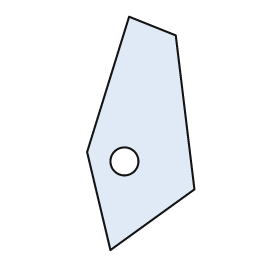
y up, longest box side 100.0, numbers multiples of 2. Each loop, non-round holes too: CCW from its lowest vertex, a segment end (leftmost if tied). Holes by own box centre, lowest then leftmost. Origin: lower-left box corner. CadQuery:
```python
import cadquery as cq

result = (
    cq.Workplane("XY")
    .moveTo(10.0, 0.0)
    .lineTo(46.0, 26.0)
    .lineTo(38.0, 92.0)
    .lineTo(18.0, 100.0)
    .lineTo(0.0, 42.0)
    .close()
    .moveTo(16.0, 38.0)
    .circle(6.0)
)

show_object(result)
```